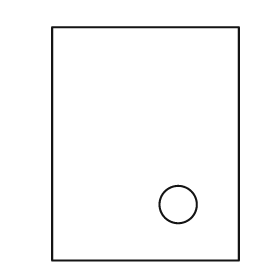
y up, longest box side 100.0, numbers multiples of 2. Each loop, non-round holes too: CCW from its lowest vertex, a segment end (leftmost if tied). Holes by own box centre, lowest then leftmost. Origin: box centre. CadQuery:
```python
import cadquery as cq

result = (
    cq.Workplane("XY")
    .moveTo(-40.0, -50.0)
    .lineTo(40.0, -50.0)
    .lineTo(40.0, 50.0)
    .lineTo(-40.0, 50.0)
    .close()
    .moveTo(14.0, -26.0)
    .circle(8.0)
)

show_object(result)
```